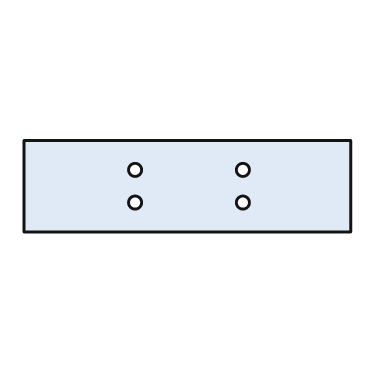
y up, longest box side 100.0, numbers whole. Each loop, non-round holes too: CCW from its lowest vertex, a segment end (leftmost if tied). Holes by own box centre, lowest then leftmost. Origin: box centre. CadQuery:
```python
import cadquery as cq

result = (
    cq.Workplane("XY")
    .moveTo(-50.0, -14.0)
    .lineTo(50.0, -14.0)
    .lineTo(50.0, 14.0)
    .lineTo(-50.0, 14.0)
    .close()
    .moveTo(-16.0, -5.0)
    .circle(2.0)
    .moveTo(17.0, -5.0)
    .circle(2.0)
    .moveTo(-16.0, 5.0)
    .circle(2.0)
    .moveTo(17.0, 5.0)
    .circle(2.0)
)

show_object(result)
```